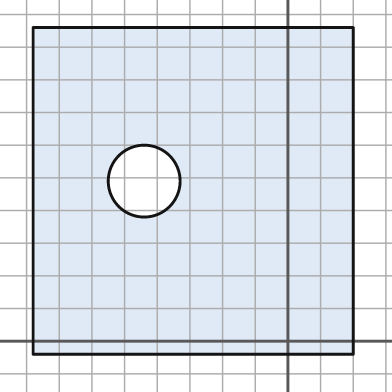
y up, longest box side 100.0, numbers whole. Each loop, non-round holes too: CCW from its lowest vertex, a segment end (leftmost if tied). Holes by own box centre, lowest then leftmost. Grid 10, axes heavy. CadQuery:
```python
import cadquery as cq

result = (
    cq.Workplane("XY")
    .moveTo(-78.0, -4.0)
    .lineTo(20.0, -4.0)
    .lineTo(20.0, 96.0)
    .lineTo(-78.0, 96.0)
    .close()
    .moveTo(-44.0, 49.0)
    .circle(11.0)
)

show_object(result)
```